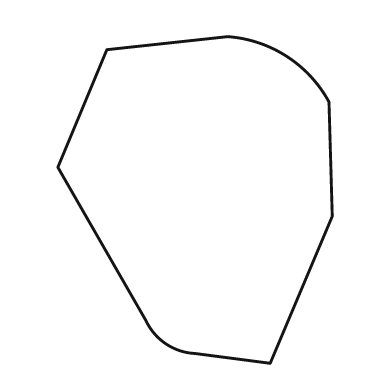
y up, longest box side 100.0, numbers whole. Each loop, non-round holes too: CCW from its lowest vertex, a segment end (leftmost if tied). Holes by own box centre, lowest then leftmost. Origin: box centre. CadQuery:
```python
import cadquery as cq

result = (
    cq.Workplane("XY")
    .moveTo(23.0, -50.0)
    .lineTo(42.0, -5.0)
    .lineTo(41.0, 30.0)
    .threePointArc((28.0, 44.0), (10.0, 50.0))
    .lineTo(-27.0, 46.0)
    .lineTo(-42.0, 10.0)
    .lineTo(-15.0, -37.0)
    .threePointArc((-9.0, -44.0), (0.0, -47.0))
    .close()
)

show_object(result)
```